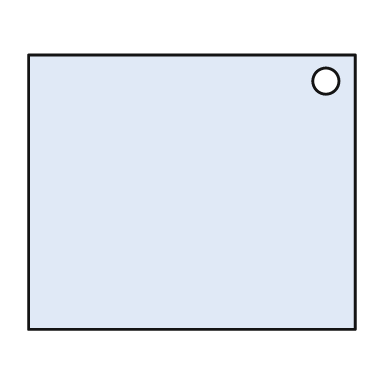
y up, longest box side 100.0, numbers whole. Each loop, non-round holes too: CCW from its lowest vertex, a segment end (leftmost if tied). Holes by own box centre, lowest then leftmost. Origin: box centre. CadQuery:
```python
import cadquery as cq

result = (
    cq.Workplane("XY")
    .moveTo(-50.0, -42.0)
    .lineTo(50.0, -42.0)
    .lineTo(50.0, 42.0)
    .lineTo(-50.0, 42.0)
    .close()
    .moveTo(41.0, 34.0)
    .circle(4.0)
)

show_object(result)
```